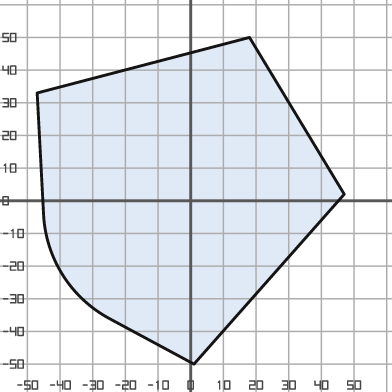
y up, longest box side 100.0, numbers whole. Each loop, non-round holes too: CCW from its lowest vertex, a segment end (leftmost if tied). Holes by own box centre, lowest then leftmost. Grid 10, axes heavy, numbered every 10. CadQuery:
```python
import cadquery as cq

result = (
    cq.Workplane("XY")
    .moveTo(1.0, -50.0)
    .lineTo(47.0, 2.0)
    .lineTo(18.0, 50.0)
    .lineTo(-47.0, 33.0)
    .lineTo(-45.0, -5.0)
    .threePointArc((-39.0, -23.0), (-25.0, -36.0))
    .close()
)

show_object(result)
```